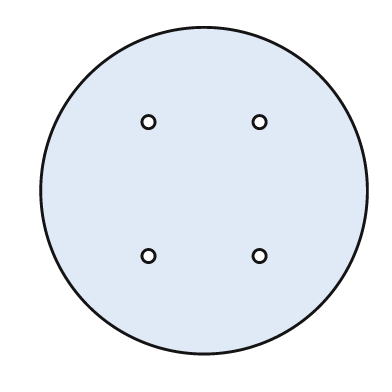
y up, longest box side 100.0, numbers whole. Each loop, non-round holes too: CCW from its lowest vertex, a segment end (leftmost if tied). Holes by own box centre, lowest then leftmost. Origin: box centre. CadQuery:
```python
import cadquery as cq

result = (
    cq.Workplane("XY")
    .moveTo(0.0, 0.0)
    .circle(50.0)
    .moveTo(-17.0, -20.0)
    .circle(2.0)
    .moveTo(17.0, -20.0)
    .circle(2.0)
    .moveTo(-17.0, 21.0)
    .circle(2.0)
    .moveTo(17.0, 21.0)
    .circle(2.0)
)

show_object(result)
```